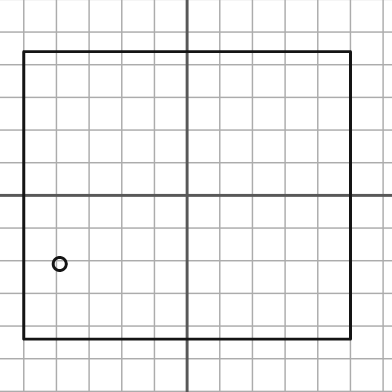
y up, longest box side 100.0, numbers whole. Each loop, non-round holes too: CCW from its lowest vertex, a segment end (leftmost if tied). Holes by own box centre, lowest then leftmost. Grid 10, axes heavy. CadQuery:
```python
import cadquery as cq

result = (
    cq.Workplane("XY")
    .moveTo(-50.0, -44.0)
    .lineTo(50.0, -44.0)
    .lineTo(50.0, 44.0)
    .lineTo(-50.0, 44.0)
    .close()
    .moveTo(-39.0, -21.0)
    .circle(2.0)
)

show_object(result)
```